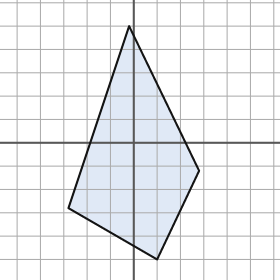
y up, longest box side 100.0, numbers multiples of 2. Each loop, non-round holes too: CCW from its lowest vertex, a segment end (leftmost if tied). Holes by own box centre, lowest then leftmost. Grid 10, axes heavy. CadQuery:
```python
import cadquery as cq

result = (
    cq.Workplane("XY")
    .moveTo(10.0, -50.0)
    .lineTo(28.0, -12.0)
    .lineTo(-2.0, 50.0)
    .lineTo(-28.0, -28.0)
    .close()
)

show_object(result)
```